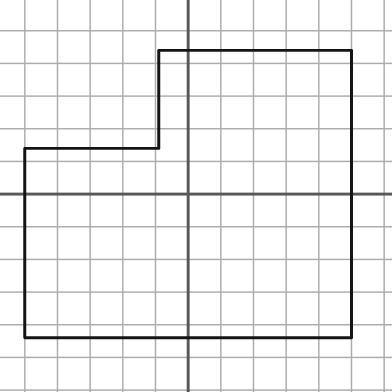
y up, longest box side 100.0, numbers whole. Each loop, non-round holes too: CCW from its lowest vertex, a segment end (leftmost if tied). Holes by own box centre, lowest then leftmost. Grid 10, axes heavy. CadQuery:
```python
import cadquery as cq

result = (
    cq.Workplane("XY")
    .moveTo(-50.0, -44.0)
    .lineTo(50.0, -44.0)
    .lineTo(50.0, 44.0)
    .lineTo(-9.0, 44.0)
    .lineTo(-9.0, 14.0)
    .lineTo(-50.0, 14.0)
    .close()
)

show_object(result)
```